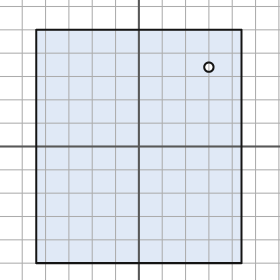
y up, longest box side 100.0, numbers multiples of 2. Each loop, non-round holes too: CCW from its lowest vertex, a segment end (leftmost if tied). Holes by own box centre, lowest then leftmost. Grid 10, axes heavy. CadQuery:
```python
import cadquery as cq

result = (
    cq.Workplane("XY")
    .moveTo(-44.0, -50.0)
    .lineTo(44.0, -50.0)
    .lineTo(44.0, 50.0)
    .lineTo(-44.0, 50.0)
    .close()
    .moveTo(30.0, 34.0)
    .circle(2.0)
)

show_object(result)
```